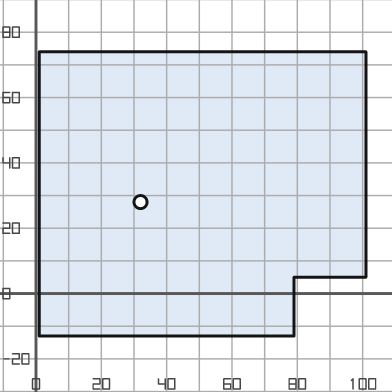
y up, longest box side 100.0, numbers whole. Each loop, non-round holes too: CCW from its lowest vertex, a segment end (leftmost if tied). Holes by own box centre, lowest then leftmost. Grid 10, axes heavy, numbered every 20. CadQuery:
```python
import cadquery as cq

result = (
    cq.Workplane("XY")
    .moveTo(1.0, -13.0)
    .lineTo(79.0, -13.0)
    .lineTo(79.0, 5.0)
    .lineTo(101.0, 5.0)
    .lineTo(101.0, 74.0)
    .lineTo(1.0, 74.0)
    .close()
    .moveTo(32.0, 28.0)
    .circle(2.0)
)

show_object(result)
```